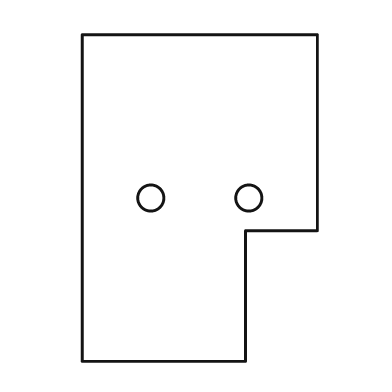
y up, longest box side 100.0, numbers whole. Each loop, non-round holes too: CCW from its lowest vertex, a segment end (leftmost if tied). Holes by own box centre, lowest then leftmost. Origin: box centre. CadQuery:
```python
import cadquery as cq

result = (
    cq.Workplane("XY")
    .moveTo(-36.0, -50.0)
    .lineTo(14.0, -50.0)
    .lineTo(14.0, -10.0)
    .lineTo(36.0, -10.0)
    .lineTo(36.0, 50.0)
    .lineTo(-36.0, 50.0)
    .close()
    .moveTo(-15.0, 0.0)
    .circle(4.0)
    .moveTo(15.0, 0.0)
    .circle(4.0)
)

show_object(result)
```